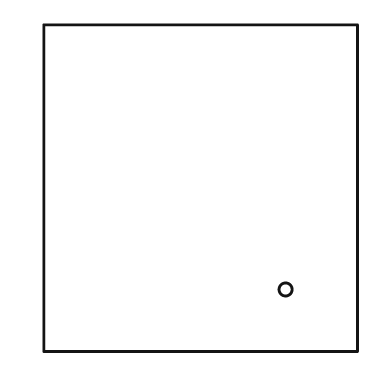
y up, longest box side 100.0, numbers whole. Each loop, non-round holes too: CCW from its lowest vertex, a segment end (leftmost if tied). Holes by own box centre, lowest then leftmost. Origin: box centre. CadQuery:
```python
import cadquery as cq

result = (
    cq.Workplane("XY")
    .moveTo(-48.0, -50.0)
    .lineTo(48.0, -50.0)
    .lineTo(48.0, 50.0)
    .lineTo(-48.0, 50.0)
    .close()
    .moveTo(26.0, -31.0)
    .circle(2.0)
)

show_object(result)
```